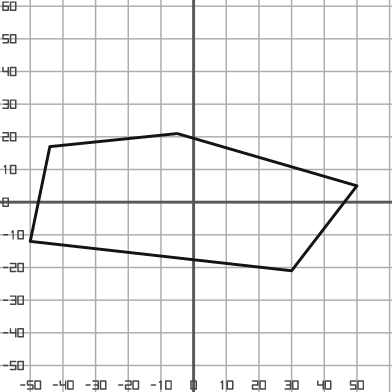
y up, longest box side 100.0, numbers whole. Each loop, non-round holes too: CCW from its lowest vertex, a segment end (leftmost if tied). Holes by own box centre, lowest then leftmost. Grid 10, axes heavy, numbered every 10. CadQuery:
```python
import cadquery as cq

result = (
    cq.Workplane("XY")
    .moveTo(30.0, -21.0)
    .lineTo(50.0, 5.0)
    .lineTo(-5.0, 21.0)
    .lineTo(-44.0, 17.0)
    .lineTo(-50.0, -12.0)
    .close()
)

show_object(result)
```